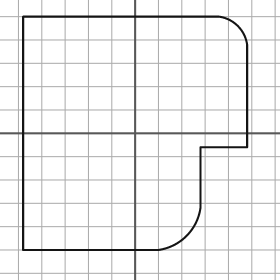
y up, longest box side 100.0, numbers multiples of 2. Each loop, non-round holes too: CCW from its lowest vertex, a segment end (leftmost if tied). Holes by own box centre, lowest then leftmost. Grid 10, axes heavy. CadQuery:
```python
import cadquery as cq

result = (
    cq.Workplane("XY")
    .moveTo(-48.0, -50.0)
    .lineTo(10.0, -50.0)
    .threePointArc((22.0, -44.0), (28.0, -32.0))
    .lineTo(28.0, -6.0)
    .lineTo(48.0, -6.0)
    .lineTo(48.0, 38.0)
    .threePointArc((44.0, 46.0), (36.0, 50.0))
    .lineTo(-48.0, 50.0)
    .close()
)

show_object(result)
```